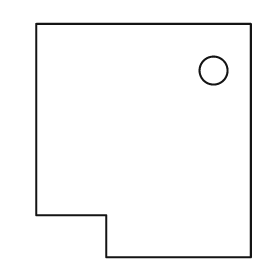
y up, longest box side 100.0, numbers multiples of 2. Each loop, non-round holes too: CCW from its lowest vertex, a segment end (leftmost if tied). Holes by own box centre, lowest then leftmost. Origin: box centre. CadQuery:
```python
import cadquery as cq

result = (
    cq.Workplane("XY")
    .moveTo(-16.0, -50.0)
    .lineTo(46.0, -50.0)
    .lineTo(46.0, 50.0)
    .lineTo(-46.0, 50.0)
    .lineTo(-46.0, -32.0)
    .lineTo(-16.0, -32.0)
    .close()
    .moveTo(30.0, 30.0)
    .circle(6.0)
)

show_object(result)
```